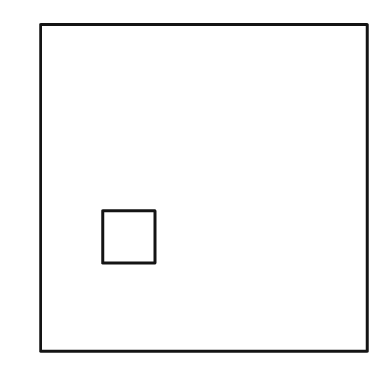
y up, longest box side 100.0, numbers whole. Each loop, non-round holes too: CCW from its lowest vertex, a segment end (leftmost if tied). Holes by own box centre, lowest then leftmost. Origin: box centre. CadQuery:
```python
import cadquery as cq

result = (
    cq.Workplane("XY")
    .moveTo(-50.0, -50.0)
    .lineTo(50.0, -50.0)
    .lineTo(50.0, 50.0)
    .lineTo(-50.0, 50.0)
    .close()
    .moveTo(-31.0, -23.0)
    .lineTo(-15.0, -23.0)
    .lineTo(-15.0, -7.0)
    .lineTo(-31.0, -7.0)
    .close()
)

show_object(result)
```